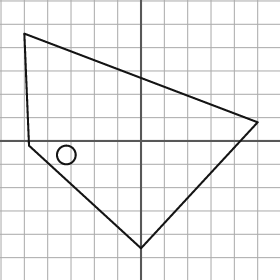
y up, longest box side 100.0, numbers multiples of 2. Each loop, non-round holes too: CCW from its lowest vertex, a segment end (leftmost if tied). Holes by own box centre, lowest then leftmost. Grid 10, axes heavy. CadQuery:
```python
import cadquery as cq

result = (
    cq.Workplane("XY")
    .moveTo(0.0, -46.0)
    .lineTo(50.0, 8.0)
    .lineTo(-50.0, 46.0)
    .lineTo(-48.0, -2.0)
    .close()
    .moveTo(-32.0, -6.0)
    .circle(4.0)
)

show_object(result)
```